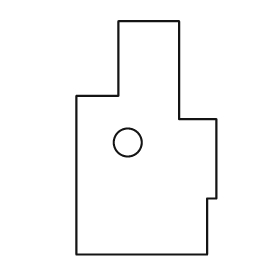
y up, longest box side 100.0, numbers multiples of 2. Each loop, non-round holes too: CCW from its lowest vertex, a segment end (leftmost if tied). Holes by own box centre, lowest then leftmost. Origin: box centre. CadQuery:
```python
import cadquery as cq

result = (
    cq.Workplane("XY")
    .moveTo(-30.0, -50.0)
    .lineTo(26.0, -50.0)
    .lineTo(26.0, -26.0)
    .lineTo(30.0, -26.0)
    .lineTo(30.0, 8.0)
    .lineTo(14.0, 8.0)
    .lineTo(14.0, 50.0)
    .lineTo(-12.0, 50.0)
    .lineTo(-12.0, 18.0)
    .lineTo(-30.0, 18.0)
    .close()
    .moveTo(-8.0, -2.0)
    .circle(6.0)
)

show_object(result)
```